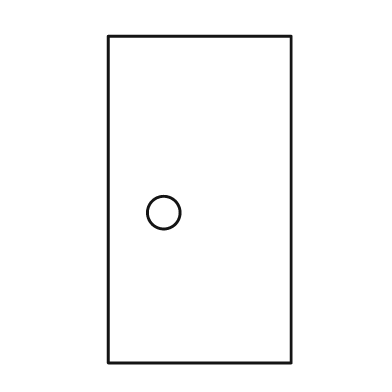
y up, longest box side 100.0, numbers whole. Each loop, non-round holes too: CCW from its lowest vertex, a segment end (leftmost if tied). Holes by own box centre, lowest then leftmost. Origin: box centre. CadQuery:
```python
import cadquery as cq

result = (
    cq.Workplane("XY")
    .moveTo(-28.0, -50.0)
    .lineTo(28.0, -50.0)
    .lineTo(28.0, 50.0)
    .lineTo(-28.0, 50.0)
    .close()
    .moveTo(-11.0, -4.0)
    .circle(5.0)
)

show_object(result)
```